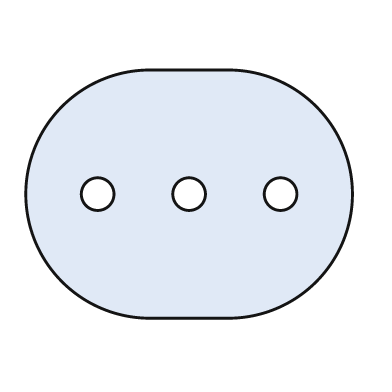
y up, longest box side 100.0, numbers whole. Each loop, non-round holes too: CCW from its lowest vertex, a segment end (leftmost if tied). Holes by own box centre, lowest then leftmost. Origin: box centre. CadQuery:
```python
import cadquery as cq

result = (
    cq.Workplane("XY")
    .moveTo(-12.0, -38.0)
    .lineTo(12.0, -38.0)
    .threePointArc((50.0, 0.0), (12.0, 38.0))
    .lineTo(-12.0, 38.0)
    .threePointArc((-50.0, 0.0), (-12.0, -38.0))
    .close()
    .moveTo(-28.0, 0.0)
    .circle(5.0)
    .moveTo(0.0, 0.0)
    .circle(5.0)
    .moveTo(28.0, 0.0)
    .circle(5.0)
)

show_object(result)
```